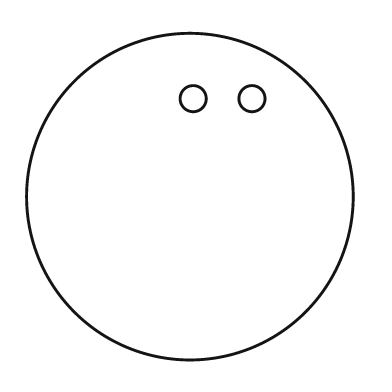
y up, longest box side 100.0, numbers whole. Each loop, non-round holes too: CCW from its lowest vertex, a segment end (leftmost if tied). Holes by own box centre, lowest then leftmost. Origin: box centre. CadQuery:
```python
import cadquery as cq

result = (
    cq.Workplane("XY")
    .moveTo(0.0, 0.0)
    .circle(50.0)
    .moveTo(1.0, 30.0)
    .circle(4.0)
    .moveTo(19.0, 30.0)
    .circle(4.0)
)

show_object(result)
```